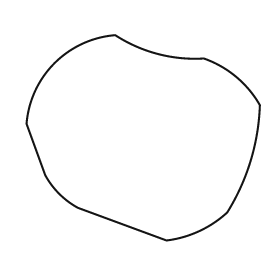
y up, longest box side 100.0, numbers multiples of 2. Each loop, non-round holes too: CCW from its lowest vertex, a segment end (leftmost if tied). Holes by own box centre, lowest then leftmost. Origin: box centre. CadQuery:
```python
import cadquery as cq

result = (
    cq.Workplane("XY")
    .moveTo(10.0, -44.0)
    .threePointArc((24.0, -40.0), (36.0, -32.0))
    .threePointArc((46.0, -10.0), (50.0, 14.0))
    .threePointArc((40.0, 26.0), (26.0, 34.0))
    .threePointArc((6.0, 36.0), (-12.0, 44.0))
    .threePointArc((-38.0, 32.0), (-50.0, 6.0))
    .lineTo(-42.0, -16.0)
    .threePointArc((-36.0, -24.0), (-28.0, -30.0))
    .close()
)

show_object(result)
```